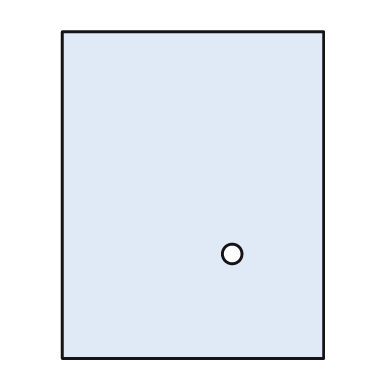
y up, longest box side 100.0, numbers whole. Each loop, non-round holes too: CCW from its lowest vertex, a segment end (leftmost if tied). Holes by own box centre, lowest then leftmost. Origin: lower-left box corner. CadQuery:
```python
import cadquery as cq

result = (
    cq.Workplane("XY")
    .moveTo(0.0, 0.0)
    .lineTo(80.0, 0.0)
    .lineTo(80.0, 100.0)
    .lineTo(0.0, 100.0)
    .close()
    .moveTo(52.0, 32.0)
    .circle(3.0)
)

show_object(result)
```